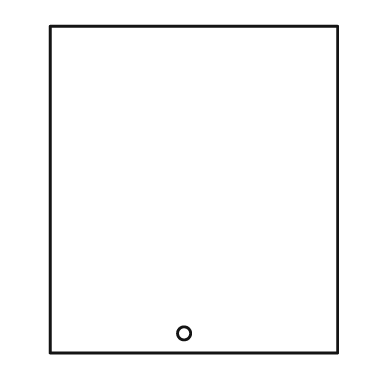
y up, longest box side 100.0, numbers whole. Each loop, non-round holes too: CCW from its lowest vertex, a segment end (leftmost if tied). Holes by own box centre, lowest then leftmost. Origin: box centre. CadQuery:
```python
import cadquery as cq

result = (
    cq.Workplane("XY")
    .moveTo(-44.0, -50.0)
    .lineTo(44.0, -50.0)
    .lineTo(44.0, 50.0)
    .lineTo(-44.0, 50.0)
    .close()
    .moveTo(-3.0, -44.0)
    .circle(2.0)
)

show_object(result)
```